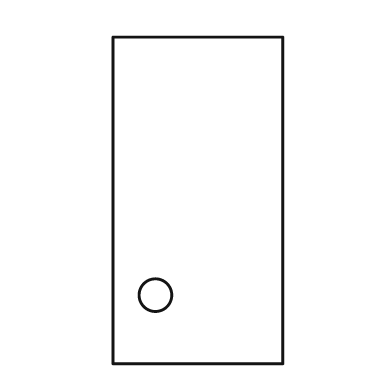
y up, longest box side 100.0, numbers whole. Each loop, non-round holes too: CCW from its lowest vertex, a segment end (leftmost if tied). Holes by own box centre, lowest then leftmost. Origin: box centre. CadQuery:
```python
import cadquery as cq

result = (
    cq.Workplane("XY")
    .moveTo(-26.0, -50.0)
    .lineTo(26.0, -50.0)
    .lineTo(26.0, 50.0)
    .lineTo(-26.0, 50.0)
    .close()
    .moveTo(-13.0, -29.0)
    .circle(5.0)
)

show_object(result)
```